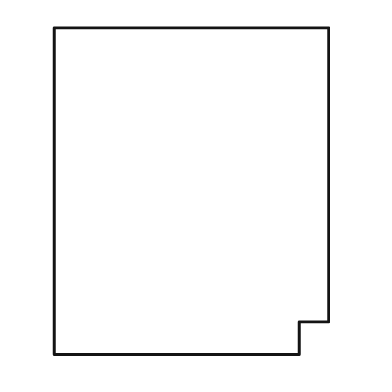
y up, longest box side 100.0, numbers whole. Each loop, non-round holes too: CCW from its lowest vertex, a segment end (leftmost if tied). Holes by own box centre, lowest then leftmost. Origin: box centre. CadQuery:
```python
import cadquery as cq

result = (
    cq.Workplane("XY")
    .moveTo(-42.0, -50.0)
    .lineTo(33.0, -50.0)
    .lineTo(33.0, -40.0)
    .lineTo(42.0, -40.0)
    .lineTo(42.0, 50.0)
    .lineTo(-42.0, 50.0)
    .close()
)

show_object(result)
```